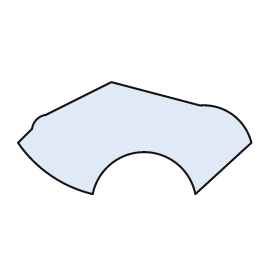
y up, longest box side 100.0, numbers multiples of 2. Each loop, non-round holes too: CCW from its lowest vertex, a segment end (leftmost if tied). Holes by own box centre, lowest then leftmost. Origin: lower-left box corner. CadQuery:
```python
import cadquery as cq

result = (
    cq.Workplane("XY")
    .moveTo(32.0, 0.0)
    .threePointArc((54.0, 18.0), (76.0, 0.0))
    .lineTo(100.0, 22.0)
    .threePointArc((92.0, 34.0), (78.0, 38.0))
    .lineTo(40.0, 48.0)
    .lineTo(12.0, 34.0)
    .threePointArc((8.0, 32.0), (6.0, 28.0))
    .lineTo(0.0, 22.0)
    .threePointArc((14.0, 8.0), (32.0, 0.0))
    .close()
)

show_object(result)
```